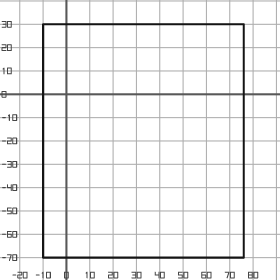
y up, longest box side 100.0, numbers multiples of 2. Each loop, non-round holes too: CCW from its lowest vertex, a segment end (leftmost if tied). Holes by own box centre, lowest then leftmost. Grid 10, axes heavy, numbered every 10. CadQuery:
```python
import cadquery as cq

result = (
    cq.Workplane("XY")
    .moveTo(-10.0, -70.0)
    .lineTo(76.0, -70.0)
    .lineTo(76.0, 30.0)
    .lineTo(-10.0, 30.0)
    .close()
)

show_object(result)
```